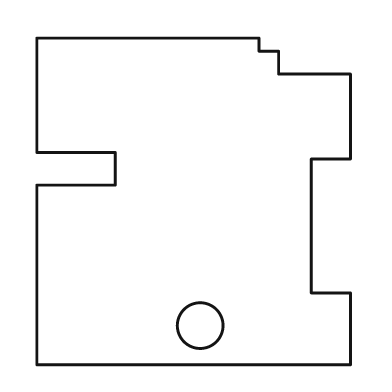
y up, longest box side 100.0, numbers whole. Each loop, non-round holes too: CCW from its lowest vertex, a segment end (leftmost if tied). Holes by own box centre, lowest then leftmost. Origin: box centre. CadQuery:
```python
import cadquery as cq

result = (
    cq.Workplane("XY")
    .moveTo(-48.0, -50.0)
    .lineTo(48.0, -50.0)
    .lineTo(48.0, -28.0)
    .lineTo(36.0, -28.0)
    .lineTo(36.0, 13.0)
    .lineTo(48.0, 13.0)
    .lineTo(48.0, 39.0)
    .lineTo(26.0, 39.0)
    .lineTo(26.0, 46.0)
    .lineTo(20.0, 46.0)
    .lineTo(20.0, 50.0)
    .lineTo(-48.0, 50.0)
    .lineTo(-48.0, 15.0)
    .lineTo(-24.0, 15.0)
    .lineTo(-24.0, 5.0)
    .lineTo(-48.0, 5.0)
    .close()
    .moveTo(2.0, -38.0)
    .circle(7.0)
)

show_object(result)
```